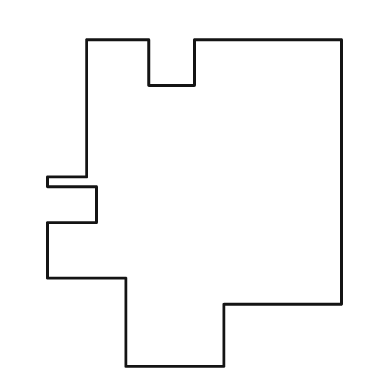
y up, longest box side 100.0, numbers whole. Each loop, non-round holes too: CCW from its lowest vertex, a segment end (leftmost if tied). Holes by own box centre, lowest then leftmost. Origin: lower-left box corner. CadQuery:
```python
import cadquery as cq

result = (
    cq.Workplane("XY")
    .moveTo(24.0, 0.0)
    .lineTo(54.0, 0.0)
    .lineTo(54.0, 19.0)
    .lineTo(90.0, 19.0)
    .lineTo(90.0, 100.0)
    .lineTo(45.0, 100.0)
    .lineTo(45.0, 86.0)
    .lineTo(31.0, 86.0)
    .lineTo(31.0, 100.0)
    .lineTo(12.0, 100.0)
    .lineTo(12.0, 58.0)
    .lineTo(0.0, 58.0)
    .lineTo(0.0, 55.0)
    .lineTo(15.0, 55.0)
    .lineTo(15.0, 44.0)
    .lineTo(0.0, 44.0)
    .lineTo(0.0, 27.0)
    .lineTo(24.0, 27.0)
    .close()
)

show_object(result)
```